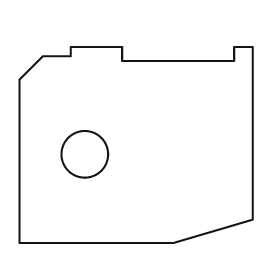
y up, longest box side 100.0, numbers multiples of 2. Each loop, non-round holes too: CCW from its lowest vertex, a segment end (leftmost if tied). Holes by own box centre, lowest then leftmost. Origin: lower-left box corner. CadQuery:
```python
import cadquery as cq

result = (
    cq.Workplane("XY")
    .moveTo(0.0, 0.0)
    .lineTo(66.0, 0.0)
    .lineTo(100.0, 10.0)
    .lineTo(100.0, 84.0)
    .lineTo(92.0, 84.0)
    .lineTo(92.0, 78.0)
    .lineTo(44.0, 78.0)
    .lineTo(44.0, 84.0)
    .lineTo(22.0, 84.0)
    .lineTo(22.0, 80.0)
    .lineTo(10.0, 80.0)
    .lineTo(0.0, 70.0)
    .close()
    .moveTo(28.0, 38.0)
    .circle(10.0)
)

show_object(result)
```